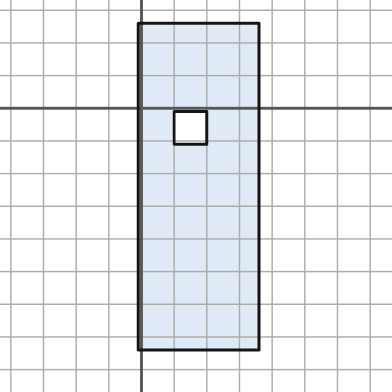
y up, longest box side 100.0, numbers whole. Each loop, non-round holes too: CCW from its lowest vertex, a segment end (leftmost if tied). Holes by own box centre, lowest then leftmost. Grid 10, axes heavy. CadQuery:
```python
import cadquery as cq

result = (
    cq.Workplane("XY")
    .moveTo(-1.0, -74.0)
    .lineTo(36.0, -74.0)
    .lineTo(36.0, 26.0)
    .lineTo(-1.0, 26.0)
    .close()
    .moveTo(10.0, -11.0)
    .lineTo(20.0, -11.0)
    .lineTo(20.0, -1.0)
    .lineTo(10.0, -1.0)
    .close()
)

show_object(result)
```